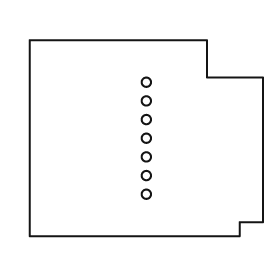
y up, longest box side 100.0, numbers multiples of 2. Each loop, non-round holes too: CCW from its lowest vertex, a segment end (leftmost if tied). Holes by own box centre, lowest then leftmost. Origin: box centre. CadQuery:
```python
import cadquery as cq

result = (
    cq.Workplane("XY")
    .moveTo(-50.0, -42.0)
    .lineTo(40.0, -42.0)
    .lineTo(40.0, -36.0)
    .lineTo(50.0, -36.0)
    .lineTo(50.0, 26.0)
    .lineTo(26.0, 26.0)
    .lineTo(26.0, 42.0)
    .lineTo(-50.0, 42.0)
    .close()
    .moveTo(0.0, -24.0)
    .circle(2.0)
    .moveTo(0.0, -16.0)
    .circle(2.0)
    .moveTo(0.0, -8.0)
    .circle(2.0)
    .moveTo(0.0, 0.0)
    .circle(2.0)
    .moveTo(0.0, 8.0)
    .circle(2.0)
    .moveTo(0.0, 16.0)
    .circle(2.0)
    .moveTo(0.0, 24.0)
    .circle(2.0)
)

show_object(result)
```